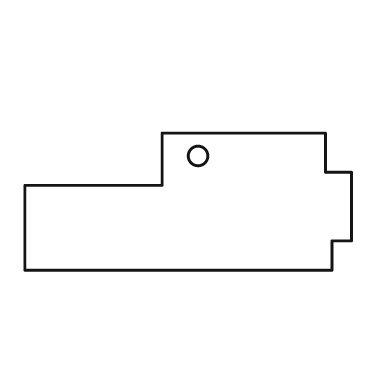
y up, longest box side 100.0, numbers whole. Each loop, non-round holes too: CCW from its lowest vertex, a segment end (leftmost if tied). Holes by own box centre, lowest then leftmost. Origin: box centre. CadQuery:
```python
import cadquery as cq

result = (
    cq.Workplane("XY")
    .moveTo(-50.0, -21.0)
    .lineTo(44.0, -21.0)
    .lineTo(44.0, -12.0)
    .lineTo(50.0, -12.0)
    .lineTo(50.0, 9.0)
    .lineTo(42.0, 9.0)
    .lineTo(42.0, 21.0)
    .lineTo(-8.0, 21.0)
    .lineTo(-8.0, 5.0)
    .lineTo(-50.0, 5.0)
    .close()
    .moveTo(3.0, 14.0)
    .circle(3.0)
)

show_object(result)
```